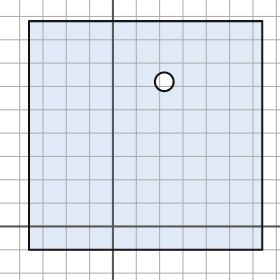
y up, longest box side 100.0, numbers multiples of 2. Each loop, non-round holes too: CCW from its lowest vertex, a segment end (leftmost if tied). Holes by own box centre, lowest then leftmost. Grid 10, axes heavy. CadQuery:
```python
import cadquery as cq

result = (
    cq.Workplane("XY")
    .moveTo(-36.0, -10.0)
    .lineTo(64.0, -10.0)
    .lineTo(64.0, 88.0)
    .lineTo(-36.0, 88.0)
    .close()
    .moveTo(22.0, 62.0)
    .circle(4.0)
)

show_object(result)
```